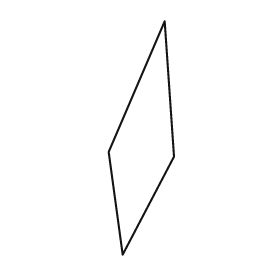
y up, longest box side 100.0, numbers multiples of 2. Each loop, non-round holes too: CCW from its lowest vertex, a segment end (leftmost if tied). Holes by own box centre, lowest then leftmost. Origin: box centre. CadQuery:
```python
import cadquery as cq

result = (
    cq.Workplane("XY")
    .moveTo(-8.0, -50.0)
    .lineTo(14.0, -8.0)
    .lineTo(10.0, 50.0)
    .lineTo(-14.0, -6.0)
    .close()
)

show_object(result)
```